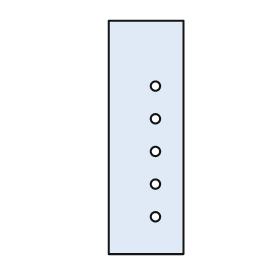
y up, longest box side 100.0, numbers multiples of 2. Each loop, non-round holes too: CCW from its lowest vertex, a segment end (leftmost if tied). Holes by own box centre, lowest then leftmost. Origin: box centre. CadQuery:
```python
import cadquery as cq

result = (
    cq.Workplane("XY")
    .moveTo(-16.0, -50.0)
    .lineTo(16.0, -50.0)
    .lineTo(16.0, 50.0)
    .lineTo(-16.0, 50.0)
    .close()
    .moveTo(4.0, -34.0)
    .circle(2.0)
    .moveTo(4.0, -20.0)
    .circle(2.0)
    .moveTo(4.0, -6.0)
    .circle(2.0)
    .moveTo(4.0, 8.0)
    .circle(2.0)
    .moveTo(4.0, 22.0)
    .circle(2.0)
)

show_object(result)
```